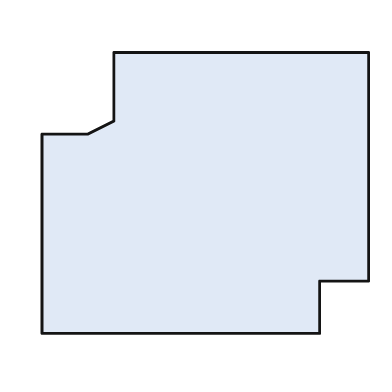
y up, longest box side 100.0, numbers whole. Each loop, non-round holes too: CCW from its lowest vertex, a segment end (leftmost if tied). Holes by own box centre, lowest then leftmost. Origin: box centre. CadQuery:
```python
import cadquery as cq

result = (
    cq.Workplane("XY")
    .moveTo(-50.0, -43.0)
    .lineTo(35.0, -43.0)
    .lineTo(35.0, -27.0)
    .lineTo(50.0, -27.0)
    .lineTo(50.0, 43.0)
    .lineTo(-28.0, 43.0)
    .lineTo(-28.0, 22.0)
    .lineTo(-36.0, 18.0)
    .lineTo(-50.0, 18.0)
    .close()
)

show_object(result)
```